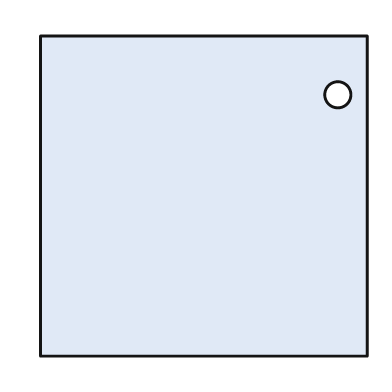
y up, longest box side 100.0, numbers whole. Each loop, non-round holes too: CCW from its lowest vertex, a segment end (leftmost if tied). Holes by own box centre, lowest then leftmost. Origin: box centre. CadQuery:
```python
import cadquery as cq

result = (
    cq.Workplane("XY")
    .moveTo(-50.0, -49.0)
    .lineTo(50.0, -49.0)
    .lineTo(50.0, 49.0)
    .lineTo(-50.0, 49.0)
    .close()
    .moveTo(41.0, 31.0)
    .circle(4.0)
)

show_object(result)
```